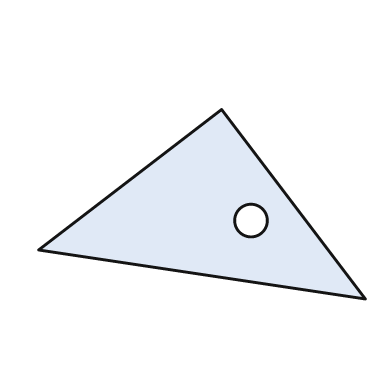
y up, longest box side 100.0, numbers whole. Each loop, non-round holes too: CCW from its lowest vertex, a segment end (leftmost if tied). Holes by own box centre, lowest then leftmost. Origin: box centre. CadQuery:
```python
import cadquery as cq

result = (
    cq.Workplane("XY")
    .moveTo(50.0, -29.0)
    .lineTo(6.0, 29.0)
    .lineTo(-50.0, -14.0)
    .close()
    .moveTo(15.0, -5.0)
    .circle(5.0)
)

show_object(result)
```